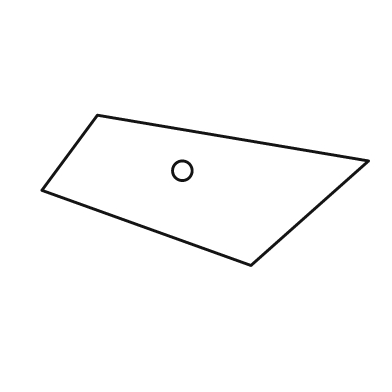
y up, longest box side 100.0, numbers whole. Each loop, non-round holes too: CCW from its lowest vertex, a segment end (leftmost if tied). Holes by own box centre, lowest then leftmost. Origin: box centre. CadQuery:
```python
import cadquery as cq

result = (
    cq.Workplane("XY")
    .moveTo(14.0, -23.0)
    .lineTo(50.0, 9.0)
    .lineTo(-33.0, 23.0)
    .lineTo(-50.0, 0.0)
    .close()
    .moveTo(-7.0, 6.0)
    .circle(3.0)
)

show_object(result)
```